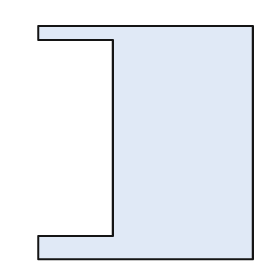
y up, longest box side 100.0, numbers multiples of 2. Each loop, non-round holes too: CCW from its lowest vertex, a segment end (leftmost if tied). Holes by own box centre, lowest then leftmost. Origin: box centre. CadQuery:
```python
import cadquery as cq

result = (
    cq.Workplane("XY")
    .moveTo(-46.0, -50.0)
    .lineTo(46.0, -50.0)
    .lineTo(46.0, 50.0)
    .lineTo(-46.0, 50.0)
    .lineTo(-46.0, 44.0)
    .lineTo(-14.0, 44.0)
    .lineTo(-14.0, -40.0)
    .lineTo(-46.0, -40.0)
    .close()
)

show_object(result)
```